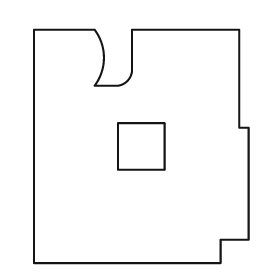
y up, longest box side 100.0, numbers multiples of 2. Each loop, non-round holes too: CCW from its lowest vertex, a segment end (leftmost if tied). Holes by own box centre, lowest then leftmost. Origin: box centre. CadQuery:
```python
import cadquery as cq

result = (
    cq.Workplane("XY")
    .moveTo(-46.0, -50.0)
    .lineTo(34.0, -50.0)
    .lineTo(34.0, -40.0)
    .lineTo(46.0, -40.0)
    .lineTo(46.0, 8.0)
    .lineTo(42.0, 8.0)
    .lineTo(42.0, 50.0)
    .lineTo(-4.0, 50.0)
    .lineTo(-4.0, 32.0)
    .threePointArc((-6.0, 28.0), (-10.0, 26.0))
    .lineTo(-20.0, 26.0)
    .threePointArc((-16.0, 38.0), (-20.0, 50.0))
    .lineTo(-46.0, 50.0)
    .close()
    .moveTo(-10.0, -10.0)
    .lineTo(10.0, -10.0)
    .lineTo(10.0, 10.0)
    .lineTo(-10.0, 10.0)
    .close()
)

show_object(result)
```